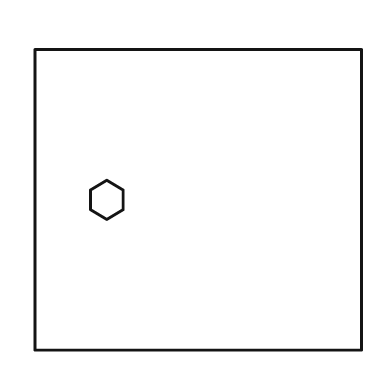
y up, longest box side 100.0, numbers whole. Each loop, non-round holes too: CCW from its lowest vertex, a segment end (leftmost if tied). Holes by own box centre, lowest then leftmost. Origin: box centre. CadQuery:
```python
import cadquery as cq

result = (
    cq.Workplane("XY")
    .moveTo(-50.0, -46.0)
    .lineTo(50.0, -46.0)
    .lineTo(50.0, 46.0)
    .lineTo(-50.0, 46.0)
    .close()
    .moveTo(-28.0, -6.0)
    .lineTo(-23.0, -3.0)
    .lineTo(-23.0, 3.0)
    .lineTo(-28.0, 6.0)
    .lineTo(-33.0, 3.0)
    .lineTo(-33.0, -3.0)
    .close()
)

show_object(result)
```